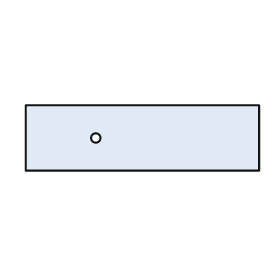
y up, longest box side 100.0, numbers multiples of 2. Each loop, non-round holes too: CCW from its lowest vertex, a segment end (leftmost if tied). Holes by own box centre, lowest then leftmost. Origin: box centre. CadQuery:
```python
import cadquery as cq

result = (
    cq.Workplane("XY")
    .moveTo(-50.0, -14.0)
    .lineTo(50.0, -14.0)
    .lineTo(50.0, 14.0)
    .lineTo(-50.0, 14.0)
    .close()
    .moveTo(-20.0, 0.0)
    .circle(2.0)
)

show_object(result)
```